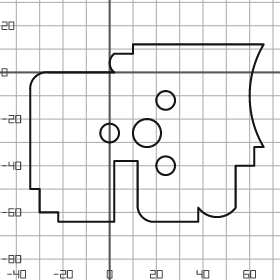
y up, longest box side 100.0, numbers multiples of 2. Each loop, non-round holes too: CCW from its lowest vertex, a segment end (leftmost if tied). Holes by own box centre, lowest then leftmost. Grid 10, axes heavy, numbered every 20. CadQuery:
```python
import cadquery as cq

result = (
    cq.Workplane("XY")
    .moveTo(-22.0, -64.0)
    .lineTo(2.0, -64.0)
    .lineTo(2.0, -38.0)
    .lineTo(12.0, -38.0)
    .lineTo(12.0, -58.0)
    .threePointArc((14.0, -62.0), (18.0, -64.0))
    .lineTo(38.0, -64.0)
    .lineTo(38.0, -58.0)
    .threePointArc((46.0, -62.0), (54.0, -58.0))
    .lineTo(54.0, -40.0)
    .lineTo(62.0, -40.0)
    .lineTo(62.0, -32.0)
    .lineTo(66.0, -32.0)
    .threePointArc((60.0, -10.0), (66.0, 12.0))
    .lineTo(10.0, 12.0)
    .lineTo(10.0, 8.0)
    .lineTo(2.0, 8.0)
    .threePointArc((0.0, 4.0), (2.0, 0.0))
    .lineTo(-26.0, 0.0)
    .threePointArc((-32.0, -2.0), (-34.0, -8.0))
    .lineTo(-34.0, -50.0)
    .lineTo(-30.0, -50.0)
    .lineTo(-30.0, -60.0)
    .lineTo(-22.0, -60.0)
    .close()
    .moveTo(24.0, -40.0)
    .circle(4.0)
    .moveTo(0.0, -26.0)
    .circle(4.0)
    .moveTo(16.0, -26.0)
    .circle(6.0)
    .moveTo(24.0, -12.0)
    .circle(4.0)
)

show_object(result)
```